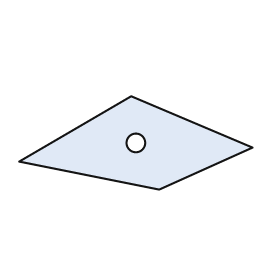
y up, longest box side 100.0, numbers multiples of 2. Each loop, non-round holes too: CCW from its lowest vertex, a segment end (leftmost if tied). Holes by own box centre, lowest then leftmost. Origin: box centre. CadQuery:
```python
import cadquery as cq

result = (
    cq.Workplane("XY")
    .moveTo(10.0, -20.0)
    .lineTo(50.0, -2.0)
    .lineTo(-2.0, 20.0)
    .lineTo(-50.0, -8.0)
    .close()
    .moveTo(0.0, 0.0)
    .circle(4.0)
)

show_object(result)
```